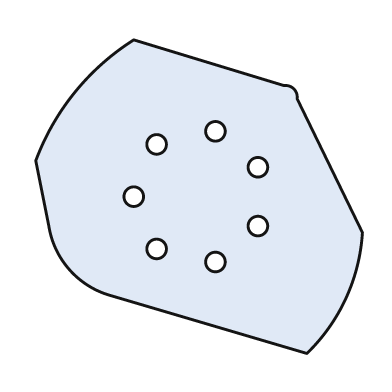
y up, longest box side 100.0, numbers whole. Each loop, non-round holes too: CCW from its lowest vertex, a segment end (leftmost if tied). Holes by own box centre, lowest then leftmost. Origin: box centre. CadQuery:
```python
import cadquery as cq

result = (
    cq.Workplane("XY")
    .moveTo(33.0, -48.0)
    .threePointArc((45.0, -31.0), (50.0, -11.0))
    .lineTo(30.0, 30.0)
    .threePointArc((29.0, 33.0), (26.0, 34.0))
    .lineTo(-20.0, 48.0)
    .threePointArc((-38.0, 32.0), (-50.0, 11.0))
    .lineTo(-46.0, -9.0)
    .threePointArc((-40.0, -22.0), (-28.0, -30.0))
    .close()
    .moveTo(5.0, -20.0)
    .circle(3.0)
    .moveTo(-13.0, -16.0)
    .circle(3.0)
    .moveTo(18.0, -9.0)
    .circle(3.0)
    .moveTo(-20.0, 0.0)
    .circle(3.0)
    .moveTo(18.0, 9.0)
    .circle(3.0)
    .moveTo(-13.0, 16.0)
    .circle(3.0)
    .moveTo(5.0, 20.0)
    .circle(3.0)
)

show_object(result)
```